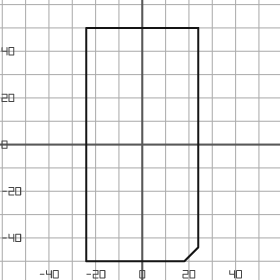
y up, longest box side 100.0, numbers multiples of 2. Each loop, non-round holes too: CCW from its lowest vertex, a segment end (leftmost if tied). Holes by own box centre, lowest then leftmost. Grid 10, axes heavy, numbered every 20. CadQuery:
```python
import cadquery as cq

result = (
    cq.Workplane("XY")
    .moveTo(-24.0, -50.0)
    .lineTo(18.0, -50.0)
    .lineTo(24.0, -44.0)
    .lineTo(24.0, 50.0)
    .lineTo(-24.0, 50.0)
    .close()
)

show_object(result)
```